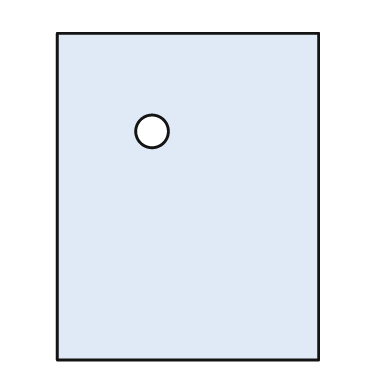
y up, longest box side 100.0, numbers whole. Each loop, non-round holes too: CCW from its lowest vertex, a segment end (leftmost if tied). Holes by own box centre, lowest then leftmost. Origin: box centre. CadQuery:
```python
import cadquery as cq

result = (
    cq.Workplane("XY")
    .moveTo(-40.0, -50.0)
    .lineTo(40.0, -50.0)
    .lineTo(40.0, 50.0)
    .lineTo(-40.0, 50.0)
    .close()
    .moveTo(-11.0, 20.0)
    .circle(5.0)
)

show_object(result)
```